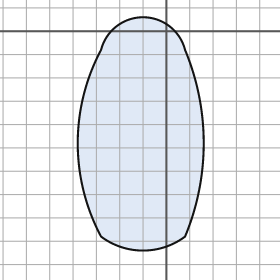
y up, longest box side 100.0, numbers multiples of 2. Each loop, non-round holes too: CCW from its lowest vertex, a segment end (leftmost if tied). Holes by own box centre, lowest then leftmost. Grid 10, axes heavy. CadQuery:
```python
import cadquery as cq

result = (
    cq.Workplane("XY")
    .moveTo(-28.0, -88.0)
    .threePointArc((-10.0, -94.0), (8.0, -88.0))
    .threePointArc((16.0, -48.0), (8.0, -8.0))
    .threePointArc((-10.0, 6.0), (-28.0, -8.0))
    .threePointArc((-38.0, -48.0), (-28.0, -88.0))
    .close()
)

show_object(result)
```